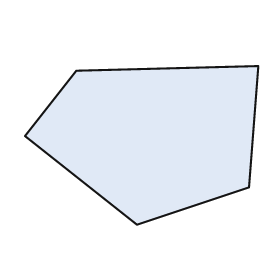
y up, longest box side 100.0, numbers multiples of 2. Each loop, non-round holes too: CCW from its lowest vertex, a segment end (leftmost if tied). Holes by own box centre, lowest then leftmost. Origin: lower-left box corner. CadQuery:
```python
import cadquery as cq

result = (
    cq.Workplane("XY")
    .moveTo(48.0, 0.0)
    .lineTo(96.0, 16.0)
    .lineTo(100.0, 68.0)
    .lineTo(22.0, 66.0)
    .lineTo(0.0, 38.0)
    .close()
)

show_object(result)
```